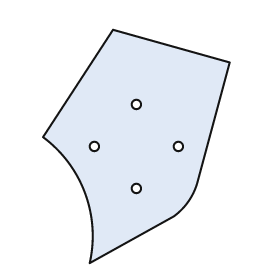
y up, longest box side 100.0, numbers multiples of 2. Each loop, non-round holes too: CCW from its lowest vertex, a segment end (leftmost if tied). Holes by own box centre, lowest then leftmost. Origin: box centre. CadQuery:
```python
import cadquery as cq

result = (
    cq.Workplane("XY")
    .moveTo(-20.0, -50.0)
    .lineTo(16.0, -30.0)
    .threePointArc((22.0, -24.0), (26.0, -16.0))
    .lineTo(40.0, 36.0)
    .lineTo(-10.0, 50.0)
    .lineTo(-40.0, 4.0)
    .threePointArc((-22.0, -20.0), (-20.0, -50.0))
    .close()
    .moveTo(0.0, -18.0)
    .circle(2.0)
    .moveTo(-18.0, 0.0)
    .circle(2.0)
    .moveTo(18.0, 0.0)
    .circle(2.0)
    .moveTo(0.0, 18.0)
    .circle(2.0)
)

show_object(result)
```